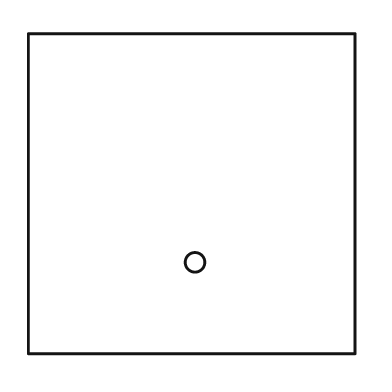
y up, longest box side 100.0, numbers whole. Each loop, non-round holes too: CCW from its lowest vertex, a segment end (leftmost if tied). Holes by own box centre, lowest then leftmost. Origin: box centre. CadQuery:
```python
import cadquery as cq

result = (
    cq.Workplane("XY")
    .moveTo(-50.0, -49.0)
    .lineTo(50.0, -49.0)
    .lineTo(50.0, 49.0)
    .lineTo(-50.0, 49.0)
    .close()
    .moveTo(1.0, -21.0)
    .circle(3.0)
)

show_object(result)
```